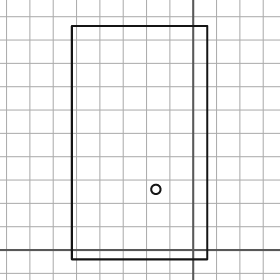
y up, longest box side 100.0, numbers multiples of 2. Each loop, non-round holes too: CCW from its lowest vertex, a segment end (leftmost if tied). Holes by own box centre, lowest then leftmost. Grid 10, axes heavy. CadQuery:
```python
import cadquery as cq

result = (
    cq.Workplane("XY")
    .moveTo(-52.0, -4.0)
    .lineTo(6.0, -4.0)
    .lineTo(6.0, 96.0)
    .lineTo(-52.0, 96.0)
    .close()
    .moveTo(-16.0, 26.0)
    .circle(2.0)
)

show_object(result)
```